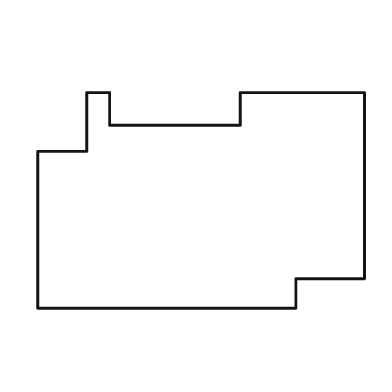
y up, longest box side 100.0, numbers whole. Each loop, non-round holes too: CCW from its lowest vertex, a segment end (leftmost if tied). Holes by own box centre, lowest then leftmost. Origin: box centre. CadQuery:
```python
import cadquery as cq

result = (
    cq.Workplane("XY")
    .moveTo(-50.0, -33.0)
    .lineTo(29.0, -33.0)
    .lineTo(29.0, -24.0)
    .lineTo(50.0, -24.0)
    .lineTo(50.0, 33.0)
    .lineTo(12.0, 33.0)
    .lineTo(12.0, 23.0)
    .lineTo(-28.0, 23.0)
    .lineTo(-28.0, 33.0)
    .lineTo(-35.0, 33.0)
    .lineTo(-35.0, 15.0)
    .lineTo(-50.0, 15.0)
    .close()
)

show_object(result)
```